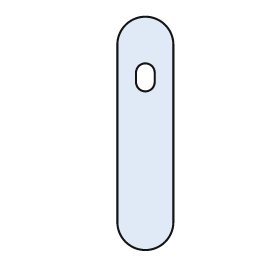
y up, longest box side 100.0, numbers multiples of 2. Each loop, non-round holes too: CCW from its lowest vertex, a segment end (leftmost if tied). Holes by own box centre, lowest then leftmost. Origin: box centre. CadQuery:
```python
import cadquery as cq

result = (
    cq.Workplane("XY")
    .moveTo(-12.0, -38.0)
    .threePointArc((0.0, -50.0), (12.0, -38.0))
    .lineTo(12.0, 38.0)
    .threePointArc((0.0, 50.0), (-12.0, 38.0))
    .close()
    .moveTo(-4.0, 22.0)
    .threePointArc((0.0, 18.0), (4.0, 22.0))
    .lineTo(4.0, 26.0)
    .threePointArc((0.0, 30.0), (-4.0, 26.0))
    .close()
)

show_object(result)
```